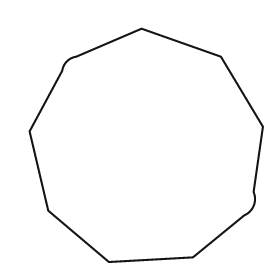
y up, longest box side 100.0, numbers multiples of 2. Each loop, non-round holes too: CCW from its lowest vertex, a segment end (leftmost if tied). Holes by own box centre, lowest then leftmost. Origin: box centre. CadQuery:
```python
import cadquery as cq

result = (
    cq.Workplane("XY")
    .moveTo(-16.0, -50.0)
    .lineTo(20.0, -48.0)
    .lineTo(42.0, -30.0)
    .threePointArc((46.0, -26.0), (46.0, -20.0))
    .lineTo(50.0, 8.0)
    .lineTo(32.0, 38.0)
    .lineTo(-2.0, 50.0)
    .lineTo(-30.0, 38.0)
    .threePointArc((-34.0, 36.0), (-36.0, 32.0))
    .lineTo(-50.0, 6.0)
    .lineTo(-42.0, -28.0)
    .close()
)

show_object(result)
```